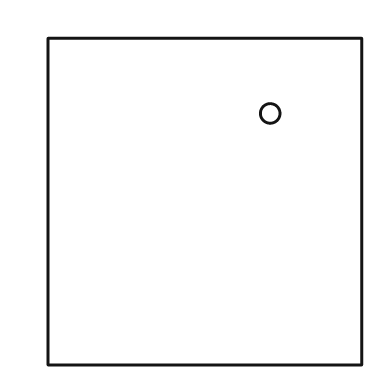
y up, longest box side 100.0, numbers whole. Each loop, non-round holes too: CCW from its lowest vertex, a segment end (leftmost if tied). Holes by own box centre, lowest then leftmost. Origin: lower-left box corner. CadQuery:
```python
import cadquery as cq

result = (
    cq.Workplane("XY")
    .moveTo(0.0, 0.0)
    .lineTo(96.0, 0.0)
    .lineTo(96.0, 100.0)
    .lineTo(0.0, 100.0)
    .close()
    .moveTo(68.0, 77.0)
    .circle(3.0)
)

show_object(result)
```